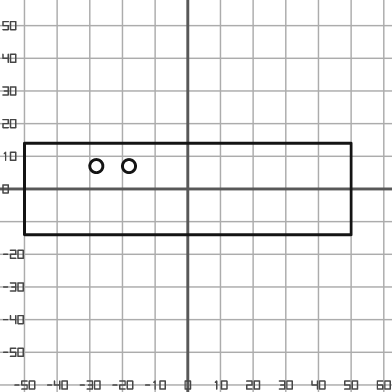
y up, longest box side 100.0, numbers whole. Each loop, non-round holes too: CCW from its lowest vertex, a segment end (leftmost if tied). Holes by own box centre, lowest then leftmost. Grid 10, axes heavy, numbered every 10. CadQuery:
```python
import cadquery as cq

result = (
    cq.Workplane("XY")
    .moveTo(-50.0, -14.0)
    .lineTo(50.0, -14.0)
    .lineTo(50.0, 14.0)
    .lineTo(-50.0, 14.0)
    .close()
    .moveTo(-28.0, 7.0)
    .circle(2.0)
    .moveTo(-18.0, 7.0)
    .circle(2.0)
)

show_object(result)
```